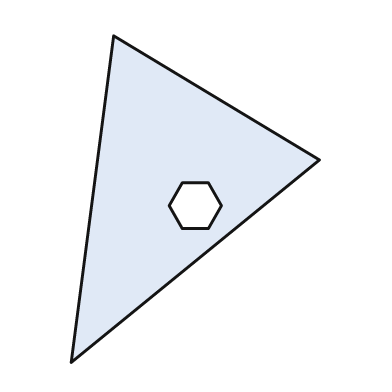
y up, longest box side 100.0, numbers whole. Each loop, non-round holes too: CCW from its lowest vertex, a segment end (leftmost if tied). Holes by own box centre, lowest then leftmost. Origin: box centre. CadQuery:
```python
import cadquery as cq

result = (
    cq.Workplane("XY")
    .moveTo(-38.0, -50.0)
    .lineTo(38.0, 12.0)
    .lineTo(-25.0, 50.0)
    .close()
    .moveTo(-4.0, -9.0)
    .lineTo(4.0, -9.0)
    .lineTo(8.0, -2.0)
    .lineTo(4.0, 5.0)
    .lineTo(-4.0, 5.0)
    .lineTo(-8.0, -2.0)
    .close()
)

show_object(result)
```